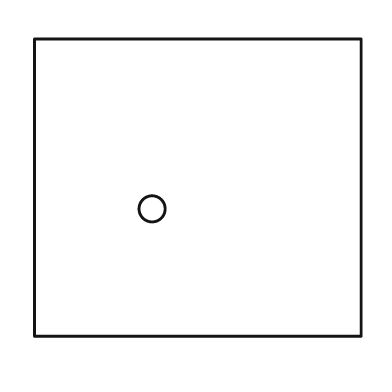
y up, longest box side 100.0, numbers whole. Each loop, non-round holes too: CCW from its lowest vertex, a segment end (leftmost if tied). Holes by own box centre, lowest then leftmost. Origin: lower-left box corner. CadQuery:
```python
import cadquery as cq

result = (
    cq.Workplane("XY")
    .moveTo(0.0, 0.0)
    .lineTo(100.0, 0.0)
    .lineTo(100.0, 91.0)
    .lineTo(0.0, 91.0)
    .close()
    .moveTo(36.0, 39.0)
    .circle(4.0)
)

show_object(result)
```